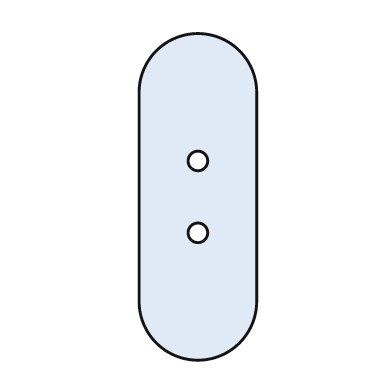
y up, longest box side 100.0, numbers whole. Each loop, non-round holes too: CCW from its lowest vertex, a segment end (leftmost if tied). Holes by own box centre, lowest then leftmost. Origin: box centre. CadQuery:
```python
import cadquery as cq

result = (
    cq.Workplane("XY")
    .moveTo(-18.0, -32.0)
    .threePointArc((0.0, -50.0), (18.0, -32.0))
    .lineTo(18.0, 32.0)
    .threePointArc((0.0, 50.0), (-18.0, 32.0))
    .close()
    .moveTo(0.0, -11.0)
    .circle(3.0)
    .moveTo(0.0, 11.0)
    .circle(3.0)
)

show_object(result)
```